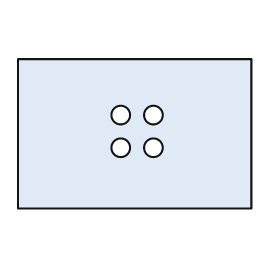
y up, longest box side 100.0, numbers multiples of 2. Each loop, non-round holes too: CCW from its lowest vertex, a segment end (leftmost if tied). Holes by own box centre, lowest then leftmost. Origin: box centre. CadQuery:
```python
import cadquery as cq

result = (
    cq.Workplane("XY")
    .moveTo(-50.0, -32.0)
    .lineTo(50.0, -32.0)
    .lineTo(50.0, 32.0)
    .lineTo(-50.0, 32.0)
    .close()
    .moveTo(-6.0, -6.0)
    .circle(4.0)
    .moveTo(8.0, -6.0)
    .circle(4.0)
    .moveTo(-6.0, 8.0)
    .circle(4.0)
    .moveTo(8.0, 8.0)
    .circle(4.0)
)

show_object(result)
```